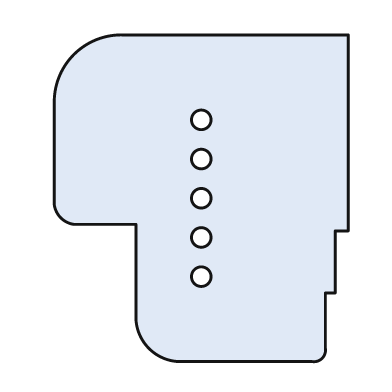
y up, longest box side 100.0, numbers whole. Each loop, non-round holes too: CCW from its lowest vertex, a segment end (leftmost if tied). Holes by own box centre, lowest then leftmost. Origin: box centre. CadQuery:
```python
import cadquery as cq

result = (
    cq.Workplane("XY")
    .moveTo(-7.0, -50.0)
    .lineTo(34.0, -50.0)
    .threePointArc((37.0, -49.0), (38.0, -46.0))
    .lineTo(38.0, -29.0)
    .lineTo(41.0, -29.0)
    .lineTo(41.0, -10.0)
    .lineTo(45.0, -10.0)
    .lineTo(45.0, 50.0)
    .lineTo(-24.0, 50.0)
    .threePointArc((-39.0, 44.0), (-45.0, 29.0))
    .lineTo(-45.0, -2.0)
    .threePointArc((-43.0, -6.0), (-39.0, -8.0))
    .lineTo(-20.0, -8.0)
    .lineTo(-20.0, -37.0)
    .threePointArc((-16.0, -46.0), (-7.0, -50.0))
    .close()
    .moveTo(0.0, -24.0)
    .circle(3.0)
    .moveTo(0.0, -12.0)
    .circle(3.0)
    .moveTo(0.0, 0.0)
    .circle(3.0)
    .moveTo(0.0, 12.0)
    .circle(3.0)
    .moveTo(0.0, 24.0)
    .circle(3.0)
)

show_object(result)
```